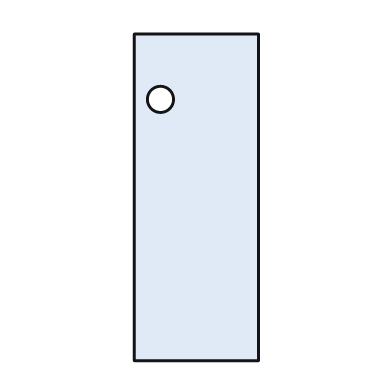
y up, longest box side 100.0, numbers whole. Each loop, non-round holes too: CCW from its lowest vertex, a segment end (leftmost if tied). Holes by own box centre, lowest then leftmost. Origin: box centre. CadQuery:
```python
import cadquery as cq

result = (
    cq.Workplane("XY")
    .moveTo(-19.0, -50.0)
    .lineTo(19.0, -50.0)
    .lineTo(19.0, 50.0)
    .lineTo(-19.0, 50.0)
    .close()
    .moveTo(-11.0, 30.0)
    .circle(4.0)
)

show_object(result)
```